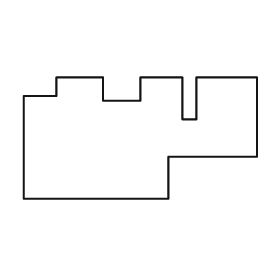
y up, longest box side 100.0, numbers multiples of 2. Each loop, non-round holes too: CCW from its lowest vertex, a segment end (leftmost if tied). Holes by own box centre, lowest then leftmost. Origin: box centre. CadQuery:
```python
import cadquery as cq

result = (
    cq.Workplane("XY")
    .moveTo(-50.0, -26.0)
    .lineTo(12.0, -26.0)
    .lineTo(12.0, -8.0)
    .lineTo(50.0, -8.0)
    .lineTo(50.0, 26.0)
    .lineTo(24.0, 26.0)
    .lineTo(24.0, 8.0)
    .lineTo(18.0, 8.0)
    .lineTo(18.0, 26.0)
    .lineTo(0.0, 26.0)
    .lineTo(0.0, 16.0)
    .lineTo(-16.0, 16.0)
    .lineTo(-16.0, 26.0)
    .lineTo(-36.0, 26.0)
    .lineTo(-36.0, 18.0)
    .lineTo(-50.0, 18.0)
    .close()
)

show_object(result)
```